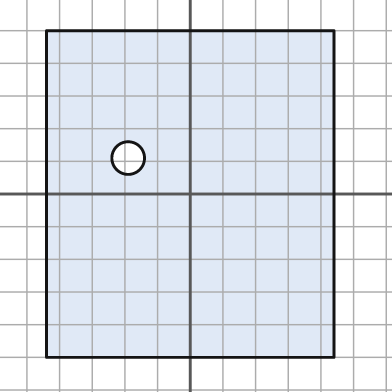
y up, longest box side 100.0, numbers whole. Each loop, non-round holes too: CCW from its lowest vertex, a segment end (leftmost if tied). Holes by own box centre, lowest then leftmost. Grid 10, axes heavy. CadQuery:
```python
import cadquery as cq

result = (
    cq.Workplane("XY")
    .moveTo(-44.0, -50.0)
    .lineTo(44.0, -50.0)
    .lineTo(44.0, 50.0)
    .lineTo(-44.0, 50.0)
    .close()
    .moveTo(-19.0, 11.0)
    .circle(5.0)
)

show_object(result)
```